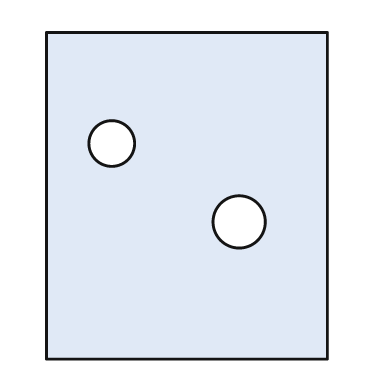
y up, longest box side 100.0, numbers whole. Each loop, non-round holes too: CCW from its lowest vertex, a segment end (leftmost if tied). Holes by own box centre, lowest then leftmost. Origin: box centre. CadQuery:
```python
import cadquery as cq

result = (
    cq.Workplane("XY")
    .moveTo(-43.0, -50.0)
    .lineTo(43.0, -50.0)
    .lineTo(43.0, 50.0)
    .lineTo(-43.0, 50.0)
    .close()
    .moveTo(16.0, -8.0)
    .circle(8.0)
    .moveTo(-23.0, 16.0)
    .circle(7.0)
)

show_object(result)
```